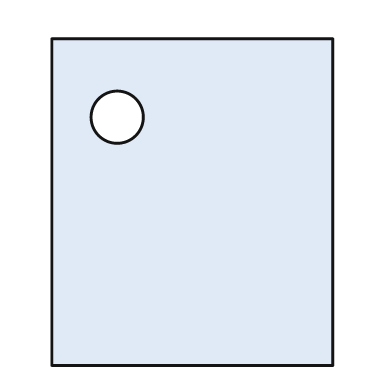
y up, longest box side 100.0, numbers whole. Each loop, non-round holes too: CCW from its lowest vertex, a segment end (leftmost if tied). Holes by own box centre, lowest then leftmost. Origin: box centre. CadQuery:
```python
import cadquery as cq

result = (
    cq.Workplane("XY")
    .moveTo(-43.0, -50.0)
    .lineTo(43.0, -50.0)
    .lineTo(43.0, 50.0)
    .lineTo(-43.0, 50.0)
    .close()
    .moveTo(-23.0, 26.0)
    .circle(8.0)
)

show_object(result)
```